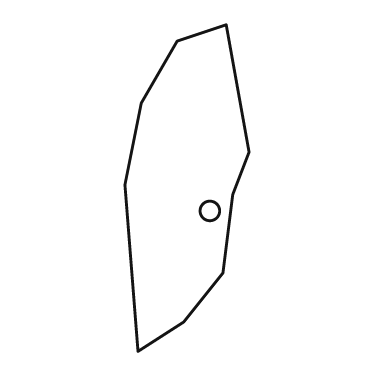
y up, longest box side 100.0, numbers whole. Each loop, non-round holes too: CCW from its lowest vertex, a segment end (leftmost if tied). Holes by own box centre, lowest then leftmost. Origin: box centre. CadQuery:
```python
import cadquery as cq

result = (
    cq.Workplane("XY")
    .moveTo(-15.0, -50.0)
    .lineTo(-1.0, -41.0)
    .lineTo(11.0, -26.0)
    .lineTo(14.0, -2.0)
    .lineTo(19.0, 11.0)
    .lineTo(12.0, 50.0)
    .lineTo(-3.0, 45.0)
    .lineTo(-14.0, 26.0)
    .lineTo(-19.0, 1.0)
    .close()
    .moveTo(7.0, -7.0)
    .circle(3.0)
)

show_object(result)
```